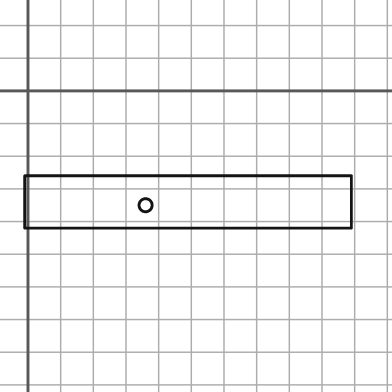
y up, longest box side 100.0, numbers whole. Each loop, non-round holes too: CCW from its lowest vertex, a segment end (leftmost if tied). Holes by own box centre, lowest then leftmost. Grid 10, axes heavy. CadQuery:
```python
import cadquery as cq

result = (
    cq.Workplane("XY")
    .moveTo(-1.0, -42.0)
    .lineTo(99.0, -42.0)
    .lineTo(99.0, -26.0)
    .lineTo(-1.0, -26.0)
    .close()
    .moveTo(36.0, -35.0)
    .circle(2.0)
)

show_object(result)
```